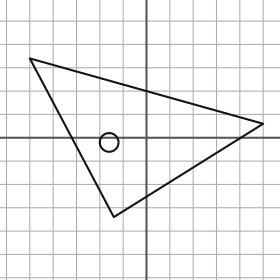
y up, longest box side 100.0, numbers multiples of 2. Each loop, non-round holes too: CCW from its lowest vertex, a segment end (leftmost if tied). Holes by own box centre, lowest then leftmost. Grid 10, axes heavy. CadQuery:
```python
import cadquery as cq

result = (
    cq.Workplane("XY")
    .moveTo(-14.0, -34.0)
    .lineTo(50.0, 6.0)
    .lineTo(-50.0, 34.0)
    .close()
    .moveTo(-16.0, -2.0)
    .circle(4.0)
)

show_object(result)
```